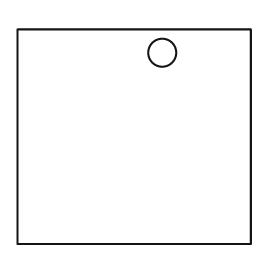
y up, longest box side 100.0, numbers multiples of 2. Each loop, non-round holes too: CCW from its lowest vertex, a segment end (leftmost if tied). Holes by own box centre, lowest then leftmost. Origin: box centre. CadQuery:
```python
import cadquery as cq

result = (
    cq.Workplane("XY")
    .moveTo(-50.0, -46.0)
    .lineTo(50.0, -46.0)
    .lineTo(50.0, 46.0)
    .lineTo(-50.0, 46.0)
    .close()
    .moveTo(12.0, 36.0)
    .circle(6.0)
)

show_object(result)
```